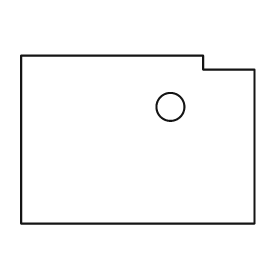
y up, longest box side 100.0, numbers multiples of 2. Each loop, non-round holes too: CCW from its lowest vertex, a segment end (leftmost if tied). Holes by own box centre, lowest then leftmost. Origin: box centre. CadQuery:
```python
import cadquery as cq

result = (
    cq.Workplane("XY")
    .moveTo(-50.0, -36.0)
    .lineTo(50.0, -36.0)
    .lineTo(50.0, 30.0)
    .lineTo(28.0, 30.0)
    .lineTo(28.0, 36.0)
    .lineTo(-50.0, 36.0)
    .close()
    .moveTo(14.0, 14.0)
    .circle(6.0)
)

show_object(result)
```